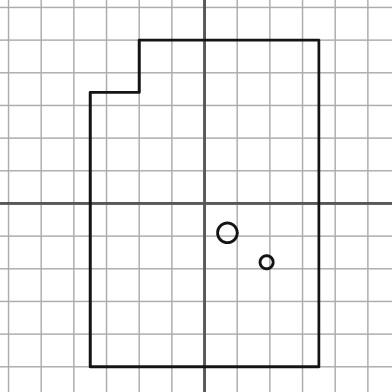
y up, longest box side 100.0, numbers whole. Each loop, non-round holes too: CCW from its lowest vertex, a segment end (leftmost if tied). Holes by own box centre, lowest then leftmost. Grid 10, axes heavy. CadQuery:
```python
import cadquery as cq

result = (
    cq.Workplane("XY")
    .moveTo(-35.0, -50.0)
    .lineTo(35.0, -50.0)
    .lineTo(35.0, 50.0)
    .lineTo(-20.0, 50.0)
    .lineTo(-20.0, 34.0)
    .lineTo(-35.0, 34.0)
    .close()
    .moveTo(19.0, -18.0)
    .circle(2.0)
    .moveTo(7.0, -9.0)
    .circle(3.0)
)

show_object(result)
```